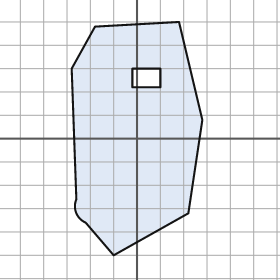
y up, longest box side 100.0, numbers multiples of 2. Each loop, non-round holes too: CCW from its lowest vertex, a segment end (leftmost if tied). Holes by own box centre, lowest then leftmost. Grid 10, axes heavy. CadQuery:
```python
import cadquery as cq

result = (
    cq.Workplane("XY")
    .moveTo(-10.0, -50.0)
    .lineTo(22.0, -32.0)
    .lineTo(28.0, 8.0)
    .lineTo(18.0, 50.0)
    .lineTo(-18.0, 48.0)
    .lineTo(-28.0, 30.0)
    .lineTo(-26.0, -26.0)
    .threePointArc((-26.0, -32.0), (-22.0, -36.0))
    .close()
    .moveTo(-2.0, 22.0)
    .lineTo(10.0, 22.0)
    .lineTo(10.0, 30.0)
    .lineTo(-2.0, 30.0)
    .close()
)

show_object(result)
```